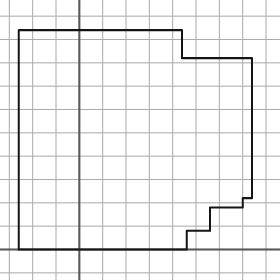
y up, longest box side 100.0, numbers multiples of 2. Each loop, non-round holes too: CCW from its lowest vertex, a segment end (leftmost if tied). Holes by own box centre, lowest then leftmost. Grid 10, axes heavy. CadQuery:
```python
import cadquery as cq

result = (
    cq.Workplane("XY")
    .moveTo(-26.0, 0.0)
    .lineTo(46.0, 0.0)
    .lineTo(46.0, 8.0)
    .lineTo(56.0, 8.0)
    .lineTo(56.0, 18.0)
    .lineTo(70.0, 18.0)
    .lineTo(70.0, 22.0)
    .lineTo(74.0, 22.0)
    .lineTo(74.0, 82.0)
    .lineTo(44.0, 82.0)
    .lineTo(44.0, 94.0)
    .lineTo(-26.0, 94.0)
    .close()
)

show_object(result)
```